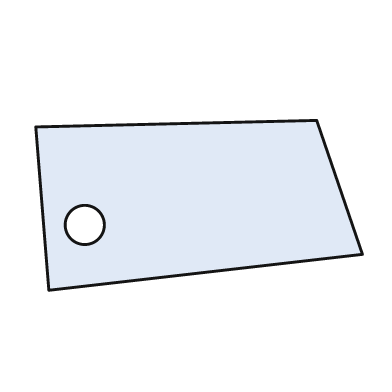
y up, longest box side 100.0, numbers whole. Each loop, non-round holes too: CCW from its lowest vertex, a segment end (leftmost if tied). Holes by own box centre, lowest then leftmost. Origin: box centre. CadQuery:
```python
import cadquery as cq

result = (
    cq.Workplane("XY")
    .moveTo(-46.0, -26.0)
    .lineTo(50.0, -15.0)
    .lineTo(36.0, 26.0)
    .lineTo(-50.0, 24.0)
    .close()
    .moveTo(-35.0, -6.0)
    .circle(6.0)
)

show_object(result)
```